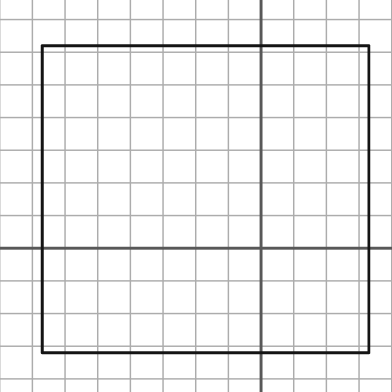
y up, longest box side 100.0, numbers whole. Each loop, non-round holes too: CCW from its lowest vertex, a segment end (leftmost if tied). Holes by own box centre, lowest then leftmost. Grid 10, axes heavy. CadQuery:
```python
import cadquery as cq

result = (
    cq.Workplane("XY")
    .moveTo(-67.0, -32.0)
    .lineTo(33.0, -32.0)
    .lineTo(33.0, 62.0)
    .lineTo(-67.0, 62.0)
    .close()
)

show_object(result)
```